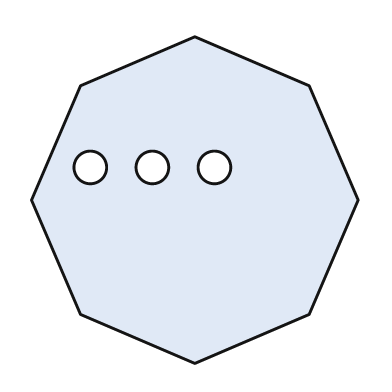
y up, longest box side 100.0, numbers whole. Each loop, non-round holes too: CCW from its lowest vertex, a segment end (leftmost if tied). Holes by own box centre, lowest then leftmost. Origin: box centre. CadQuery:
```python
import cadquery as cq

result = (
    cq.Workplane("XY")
    .moveTo(0.0, -50.0)
    .lineTo(35.0, -35.0)
    .lineTo(50.0, 0.0)
    .lineTo(35.0, 35.0)
    .lineTo(0.0, 50.0)
    .lineTo(-35.0, 35.0)
    .lineTo(-50.0, 0.0)
    .lineTo(-35.0, -35.0)
    .close()
    .moveTo(-32.0, 10.0)
    .circle(5.0)
    .moveTo(-13.0, 10.0)
    .circle(5.0)
    .moveTo(6.0, 10.0)
    .circle(5.0)
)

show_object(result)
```